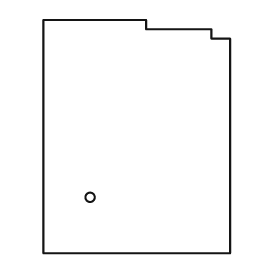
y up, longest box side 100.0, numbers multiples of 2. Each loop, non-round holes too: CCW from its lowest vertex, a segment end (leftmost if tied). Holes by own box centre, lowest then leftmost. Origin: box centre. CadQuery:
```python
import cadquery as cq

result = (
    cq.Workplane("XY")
    .moveTo(-40.0, -50.0)
    .lineTo(40.0, -50.0)
    .lineTo(40.0, 42.0)
    .lineTo(32.0, 42.0)
    .lineTo(32.0, 46.0)
    .lineTo(4.0, 46.0)
    .lineTo(4.0, 50.0)
    .lineTo(-40.0, 50.0)
    .close()
    .moveTo(-20.0, -26.0)
    .circle(2.0)
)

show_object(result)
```